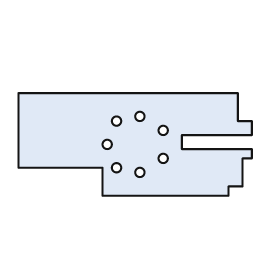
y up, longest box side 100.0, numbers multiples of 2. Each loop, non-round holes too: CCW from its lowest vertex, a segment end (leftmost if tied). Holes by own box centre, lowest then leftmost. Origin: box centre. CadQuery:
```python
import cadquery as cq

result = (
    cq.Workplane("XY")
    .moveTo(-14.0, -22.0)
    .lineTo(40.0, -22.0)
    .lineTo(40.0, -18.0)
    .lineTo(46.0, -18.0)
    .lineTo(46.0, -6.0)
    .lineTo(50.0, -6.0)
    .lineTo(50.0, -2.0)
    .lineTo(20.0, -2.0)
    .lineTo(20.0, 4.0)
    .lineTo(50.0, 4.0)
    .lineTo(50.0, 10.0)
    .lineTo(44.0, 10.0)
    .lineTo(44.0, 22.0)
    .lineTo(-50.0, 22.0)
    .lineTo(-50.0, -10.0)
    .lineTo(-14.0, -10.0)
    .close()
    .moveTo(2.0, -12.0)
    .circle(2.0)
    .moveTo(-8.0, -10.0)
    .circle(2.0)
    .moveTo(12.0, -6.0)
    .circle(2.0)
    .moveTo(-12.0, 0.0)
    .circle(2.0)
    .moveTo(12.0, 6.0)
    .circle(2.0)
    .moveTo(-8.0, 10.0)
    .circle(2.0)
    .moveTo(2.0, 12.0)
    .circle(2.0)
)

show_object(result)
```